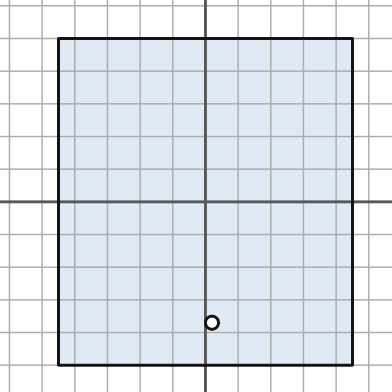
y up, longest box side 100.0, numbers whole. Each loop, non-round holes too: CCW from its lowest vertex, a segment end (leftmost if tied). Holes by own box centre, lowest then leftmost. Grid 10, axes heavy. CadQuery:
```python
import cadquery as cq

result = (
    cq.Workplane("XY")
    .moveTo(-45.0, -50.0)
    .lineTo(45.0, -50.0)
    .lineTo(45.0, 50.0)
    .lineTo(-45.0, 50.0)
    .close()
    .moveTo(2.0, -37.0)
    .circle(2.0)
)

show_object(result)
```